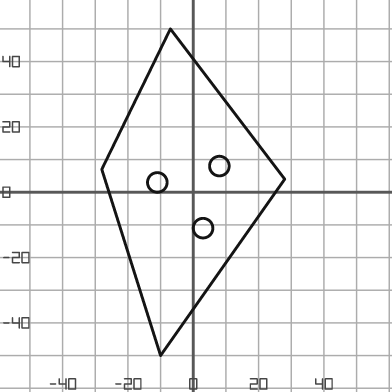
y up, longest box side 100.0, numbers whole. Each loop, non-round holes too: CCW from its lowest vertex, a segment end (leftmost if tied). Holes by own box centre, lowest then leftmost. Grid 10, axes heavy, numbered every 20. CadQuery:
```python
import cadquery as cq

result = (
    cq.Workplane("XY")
    .moveTo(-10.0, -50.0)
    .lineTo(28.0, 4.0)
    .lineTo(-7.0, 50.0)
    .lineTo(-28.0, 7.0)
    .close()
    .moveTo(3.0, -11.0)
    .circle(3.0)
    .moveTo(-11.0, 3.0)
    .circle(3.0)
    .moveTo(8.0, 8.0)
    .circle(3.0)
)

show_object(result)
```